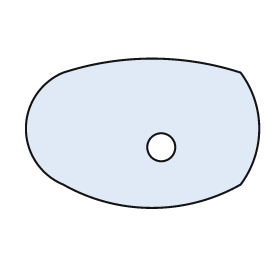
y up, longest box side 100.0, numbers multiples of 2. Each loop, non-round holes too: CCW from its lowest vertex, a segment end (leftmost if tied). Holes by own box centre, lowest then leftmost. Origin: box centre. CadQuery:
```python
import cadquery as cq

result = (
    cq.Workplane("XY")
    .moveTo(-34.0, -22.0)
    .threePointArc((4.0, -32.0), (42.0, -22.0))
    .threePointArc((50.0, 2.0), (42.0, 26.0))
    .threePointArc((4.0, 32.0), (-34.0, 26.0))
    .threePointArc((-50.0, 2.0), (-34.0, -22.0))
    .close()
    .moveTo(8.0, -6.0)
    .circle(6.0)
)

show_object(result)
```